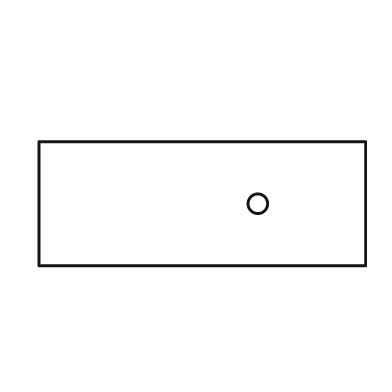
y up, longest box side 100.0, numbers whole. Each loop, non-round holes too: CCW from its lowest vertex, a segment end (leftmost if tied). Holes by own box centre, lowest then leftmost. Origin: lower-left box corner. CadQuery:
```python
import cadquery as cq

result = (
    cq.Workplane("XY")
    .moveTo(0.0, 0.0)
    .lineTo(100.0, 0.0)
    .lineTo(100.0, 38.0)
    .lineTo(0.0, 38.0)
    .close()
    .moveTo(67.0, 19.0)
    .circle(3.0)
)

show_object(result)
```